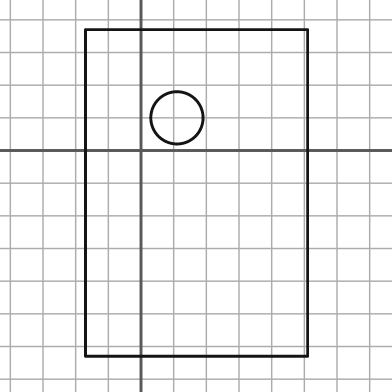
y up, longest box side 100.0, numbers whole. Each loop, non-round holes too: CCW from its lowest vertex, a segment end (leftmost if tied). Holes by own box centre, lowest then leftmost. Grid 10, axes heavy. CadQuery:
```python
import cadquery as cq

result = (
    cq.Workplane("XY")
    .moveTo(-17.0, -63.0)
    .lineTo(51.0, -63.0)
    .lineTo(51.0, 37.0)
    .lineTo(-17.0, 37.0)
    .close()
    .moveTo(11.0, 10.0)
    .circle(8.0)
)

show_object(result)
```